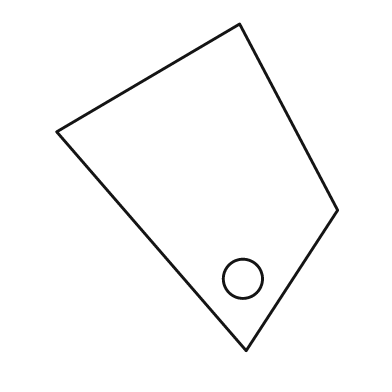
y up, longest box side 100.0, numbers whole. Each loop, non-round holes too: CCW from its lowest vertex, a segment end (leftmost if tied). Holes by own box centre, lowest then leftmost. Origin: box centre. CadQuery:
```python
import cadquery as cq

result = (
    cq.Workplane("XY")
    .moveTo(15.0, -50.0)
    .lineTo(43.0, -7.0)
    .lineTo(13.0, 50.0)
    .lineTo(-43.0, 17.0)
    .close()
    .moveTo(14.0, -28.0)
    .circle(6.0)
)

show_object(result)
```